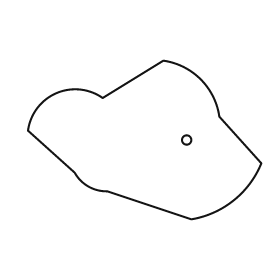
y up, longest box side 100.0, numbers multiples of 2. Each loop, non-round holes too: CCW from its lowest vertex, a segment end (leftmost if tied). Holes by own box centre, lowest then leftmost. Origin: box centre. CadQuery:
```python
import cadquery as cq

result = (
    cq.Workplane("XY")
    .moveTo(20.0, -34.0)
    .threePointArc((38.0, -26.0), (50.0, -10.0))
    .lineTo(32.0, 10.0)
    .threePointArc((24.0, 26.0), (8.0, 34.0))
    .lineTo(-18.0, 18.0)
    .threePointArc((-38.0, 20.0), (-50.0, 4.0))
    .lineTo(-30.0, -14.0)
    .threePointArc((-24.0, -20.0), (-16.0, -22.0))
    .close()
    .moveTo(18.0, 0.0)
    .circle(2.0)
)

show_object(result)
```